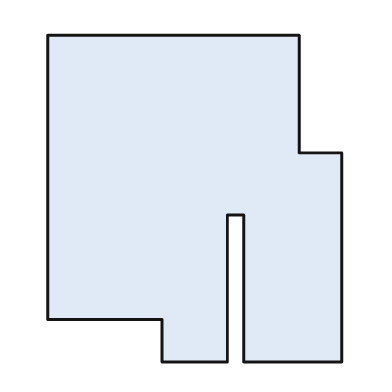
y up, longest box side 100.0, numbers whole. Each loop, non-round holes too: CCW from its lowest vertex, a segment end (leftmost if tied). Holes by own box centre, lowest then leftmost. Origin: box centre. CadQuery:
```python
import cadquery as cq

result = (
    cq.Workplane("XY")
    .moveTo(-10.0, -50.0)
    .lineTo(10.0, -50.0)
    .lineTo(10.0, -5.0)
    .lineTo(15.0, -5.0)
    .lineTo(15.0, -50.0)
    .lineTo(45.0, -50.0)
    .lineTo(45.0, 14.0)
    .lineTo(32.0, 14.0)
    .lineTo(32.0, 50.0)
    .lineTo(-45.0, 50.0)
    .lineTo(-45.0, -37.0)
    .lineTo(-10.0, -37.0)
    .close()
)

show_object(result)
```